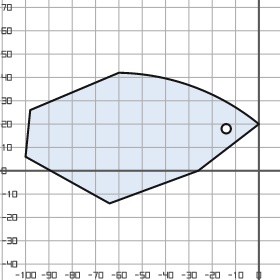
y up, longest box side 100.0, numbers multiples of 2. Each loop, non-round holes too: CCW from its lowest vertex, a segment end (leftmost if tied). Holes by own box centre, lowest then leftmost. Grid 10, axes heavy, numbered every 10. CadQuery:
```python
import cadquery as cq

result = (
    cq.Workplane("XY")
    .moveTo(-64.0, -14.0)
    .lineTo(-26.0, 0.0)
    .lineTo(0.0, 20.0)
    .threePointArc((-28.0, 36.0), (-60.0, 42.0))
    .lineTo(-98.0, 26.0)
    .lineTo(-100.0, 6.0)
    .close()
    .moveTo(-14.0, 18.0)
    .circle(2.0)
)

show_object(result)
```